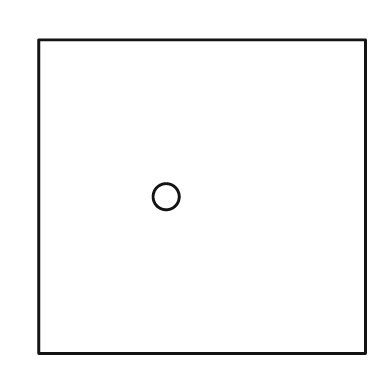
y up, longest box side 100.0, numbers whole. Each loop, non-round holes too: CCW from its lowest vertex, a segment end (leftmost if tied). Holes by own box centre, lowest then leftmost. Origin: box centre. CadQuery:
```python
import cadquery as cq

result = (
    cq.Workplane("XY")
    .moveTo(-50.0, -48.0)
    .lineTo(50.0, -48.0)
    .lineTo(50.0, 48.0)
    .lineTo(-50.0, 48.0)
    .close()
    .moveTo(-11.0, 0.0)
    .circle(4.0)
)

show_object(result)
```